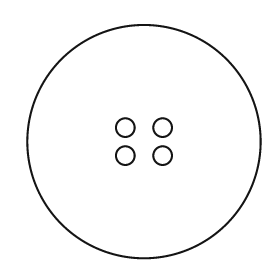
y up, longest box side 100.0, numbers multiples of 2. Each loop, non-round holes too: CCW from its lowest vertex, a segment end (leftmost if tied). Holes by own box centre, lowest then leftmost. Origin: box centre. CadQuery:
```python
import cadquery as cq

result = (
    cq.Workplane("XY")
    .moveTo(0.0, 0.0)
    .circle(50.0)
    .moveTo(-8.0, -6.0)
    .circle(4.0)
    .moveTo(8.0, -6.0)
    .circle(4.0)
    .moveTo(-8.0, 6.0)
    .circle(4.0)
    .moveTo(8.0, 6.0)
    .circle(4.0)
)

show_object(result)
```